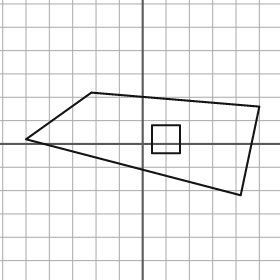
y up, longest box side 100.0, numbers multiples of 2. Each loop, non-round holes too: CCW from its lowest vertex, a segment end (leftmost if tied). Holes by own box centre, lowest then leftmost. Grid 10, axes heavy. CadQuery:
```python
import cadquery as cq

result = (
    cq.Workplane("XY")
    .moveTo(42.0, -22.0)
    .lineTo(50.0, 16.0)
    .lineTo(-22.0, 22.0)
    .lineTo(-50.0, 2.0)
    .close()
    .moveTo(4.0, -4.0)
    .lineTo(16.0, -4.0)
    .lineTo(16.0, 8.0)
    .lineTo(4.0, 8.0)
    .close()
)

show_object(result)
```